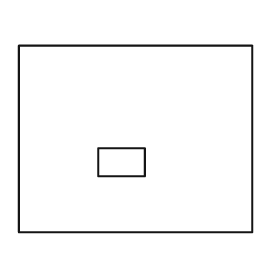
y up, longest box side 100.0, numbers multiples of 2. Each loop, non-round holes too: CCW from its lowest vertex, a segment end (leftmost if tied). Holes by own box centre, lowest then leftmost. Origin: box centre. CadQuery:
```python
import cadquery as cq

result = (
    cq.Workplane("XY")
    .moveTo(-50.0, -40.0)
    .lineTo(50.0, -40.0)
    .lineTo(50.0, 40.0)
    .lineTo(-50.0, 40.0)
    .close()
    .moveTo(-16.0, -16.0)
    .lineTo(4.0, -16.0)
    .lineTo(4.0, -4.0)
    .lineTo(-16.0, -4.0)
    .close()
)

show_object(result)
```